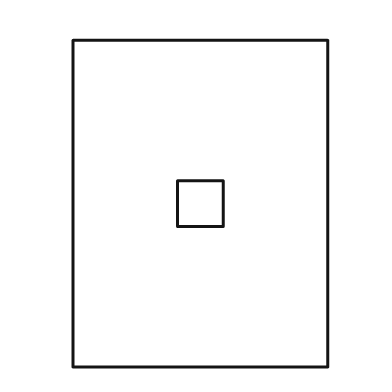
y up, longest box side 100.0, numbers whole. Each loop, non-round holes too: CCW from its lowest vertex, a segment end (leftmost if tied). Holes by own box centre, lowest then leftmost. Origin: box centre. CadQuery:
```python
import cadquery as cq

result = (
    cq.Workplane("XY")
    .moveTo(-39.0, -50.0)
    .lineTo(39.0, -50.0)
    .lineTo(39.0, 50.0)
    .lineTo(-39.0, 50.0)
    .close()
    .moveTo(-7.0, -7.0)
    .lineTo(7.0, -7.0)
    .lineTo(7.0, 7.0)
    .lineTo(-7.0, 7.0)
    .close()
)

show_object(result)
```